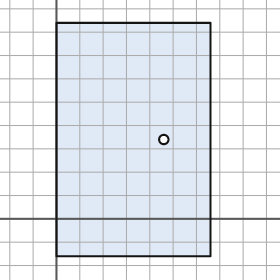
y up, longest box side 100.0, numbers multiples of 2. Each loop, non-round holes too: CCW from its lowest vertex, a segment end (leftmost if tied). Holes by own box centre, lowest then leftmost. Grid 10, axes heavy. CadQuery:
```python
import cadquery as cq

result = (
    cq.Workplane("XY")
    .moveTo(0.0, -16.0)
    .lineTo(66.0, -16.0)
    .lineTo(66.0, 84.0)
    .lineTo(0.0, 84.0)
    .close()
    .moveTo(46.0, 34.0)
    .circle(2.0)
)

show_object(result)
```